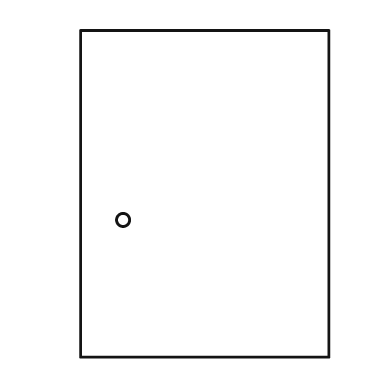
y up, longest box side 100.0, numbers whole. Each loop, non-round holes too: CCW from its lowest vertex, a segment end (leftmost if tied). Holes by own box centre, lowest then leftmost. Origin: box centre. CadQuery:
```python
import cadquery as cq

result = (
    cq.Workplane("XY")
    .moveTo(-38.0, -50.0)
    .lineTo(38.0, -50.0)
    .lineTo(38.0, 50.0)
    .lineTo(-38.0, 50.0)
    .close()
    .moveTo(-25.0, -8.0)
    .circle(2.0)
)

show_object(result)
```